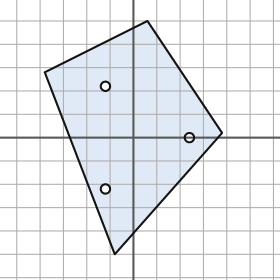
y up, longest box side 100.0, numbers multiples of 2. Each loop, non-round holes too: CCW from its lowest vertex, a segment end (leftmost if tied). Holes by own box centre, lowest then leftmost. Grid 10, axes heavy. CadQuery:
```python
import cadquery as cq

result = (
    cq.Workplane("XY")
    .moveTo(-8.0, -50.0)
    .lineTo(38.0, 2.0)
    .lineTo(6.0, 50.0)
    .lineTo(-38.0, 28.0)
    .close()
    .moveTo(-12.0, -22.0)
    .circle(2.0)
    .moveTo(24.0, 0.0)
    .circle(2.0)
    .moveTo(-12.0, 22.0)
    .circle(2.0)
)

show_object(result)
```